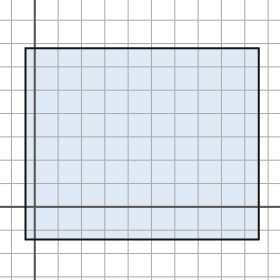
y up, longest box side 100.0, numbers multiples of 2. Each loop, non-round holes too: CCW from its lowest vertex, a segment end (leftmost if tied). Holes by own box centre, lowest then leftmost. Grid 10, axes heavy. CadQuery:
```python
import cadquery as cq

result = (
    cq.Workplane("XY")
    .moveTo(-4.0, -14.0)
    .lineTo(96.0, -14.0)
    .lineTo(96.0, 68.0)
    .lineTo(-4.0, 68.0)
    .close()
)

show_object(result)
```